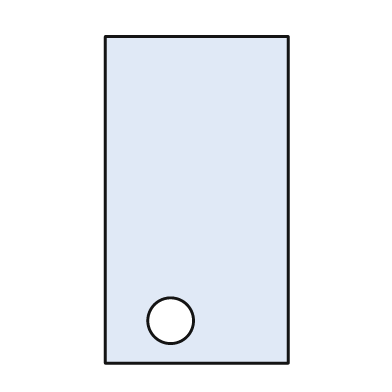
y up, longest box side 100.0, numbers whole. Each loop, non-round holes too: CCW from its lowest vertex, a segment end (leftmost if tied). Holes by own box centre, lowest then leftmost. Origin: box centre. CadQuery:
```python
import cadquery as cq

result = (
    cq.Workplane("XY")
    .moveTo(-28.0, -50.0)
    .lineTo(28.0, -50.0)
    .lineTo(28.0, 50.0)
    .lineTo(-28.0, 50.0)
    .close()
    .moveTo(-8.0, -37.0)
    .circle(7.0)
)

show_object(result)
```